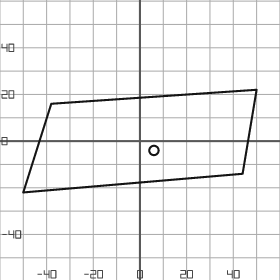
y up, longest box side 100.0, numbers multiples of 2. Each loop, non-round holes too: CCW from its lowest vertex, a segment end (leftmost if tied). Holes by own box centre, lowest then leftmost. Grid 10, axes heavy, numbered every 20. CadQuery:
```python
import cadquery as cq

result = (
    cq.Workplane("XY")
    .moveTo(-50.0, -22.0)
    .lineTo(44.0, -14.0)
    .lineTo(50.0, 22.0)
    .lineTo(-38.0, 16.0)
    .close()
    .moveTo(6.0, -4.0)
    .circle(2.0)
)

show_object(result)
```